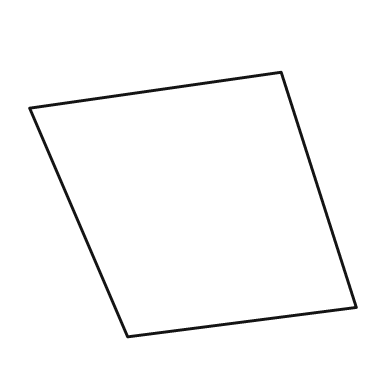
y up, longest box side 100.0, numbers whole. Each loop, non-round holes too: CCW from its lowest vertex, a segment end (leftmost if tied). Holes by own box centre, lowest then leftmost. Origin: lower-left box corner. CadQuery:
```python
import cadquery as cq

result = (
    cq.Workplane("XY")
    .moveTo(30.0, 0.0)
    .lineTo(100.0, 9.0)
    .lineTo(77.0, 81.0)
    .lineTo(0.0, 70.0)
    .close()
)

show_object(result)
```